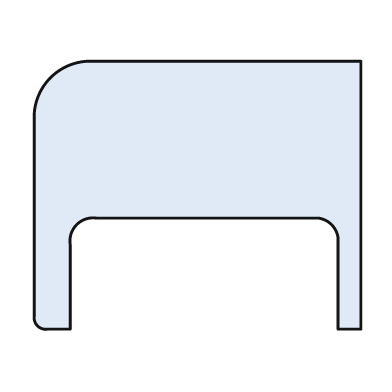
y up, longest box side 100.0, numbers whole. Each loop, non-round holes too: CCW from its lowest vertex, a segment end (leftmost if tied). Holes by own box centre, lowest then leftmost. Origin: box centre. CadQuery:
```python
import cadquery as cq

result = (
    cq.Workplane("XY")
    .moveTo(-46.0, -41.0)
    .lineTo(-39.0, -41.0)
    .lineTo(-39.0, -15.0)
    .threePointArc((-37.0, -9.0), (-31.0, -7.0))
    .lineTo(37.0, -7.0)
    .threePointArc((41.0, -9.0), (43.0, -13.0))
    .lineTo(43.0, -41.0)
    .lineTo(50.0, -41.0)
    .lineTo(50.0, 41.0)
    .lineTo(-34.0, 41.0)
    .threePointArc((-45.0, 36.0), (-50.0, 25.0))
    .lineTo(-50.0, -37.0)
    .threePointArc((-49.0, -40.0), (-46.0, -41.0))
    .close()
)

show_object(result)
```